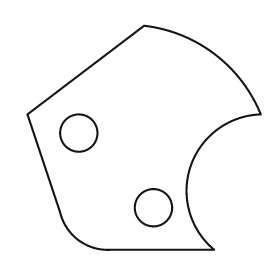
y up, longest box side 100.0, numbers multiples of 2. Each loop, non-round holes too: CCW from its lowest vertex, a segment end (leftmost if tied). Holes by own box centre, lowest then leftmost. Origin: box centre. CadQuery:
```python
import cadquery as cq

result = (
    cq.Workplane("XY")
    .moveTo(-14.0, -48.0)
    .lineTo(30.0, -48.0)
    .threePointArc((20.0, -12.0), (50.0, 10.0))
    .threePointArc((30.0, 36.0), (0.0, 48.0))
    .lineTo(-50.0, 10.0)
    .lineTo(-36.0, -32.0)
    .threePointArc((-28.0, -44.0), (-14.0, -48.0))
    .close()
    .moveTo(4.0, -30.0)
    .circle(8.0)
    .moveTo(-28.0, 2.0)
    .circle(8.0)
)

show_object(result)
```